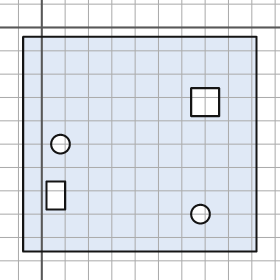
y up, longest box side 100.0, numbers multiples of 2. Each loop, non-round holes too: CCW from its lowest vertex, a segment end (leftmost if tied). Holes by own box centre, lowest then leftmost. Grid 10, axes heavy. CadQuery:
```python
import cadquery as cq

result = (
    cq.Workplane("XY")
    .moveTo(-8.0, -96.0)
    .lineTo(92.0, -96.0)
    .lineTo(92.0, -4.0)
    .lineTo(-8.0, -4.0)
    .close()
    .moveTo(68.0, -80.0)
    .circle(4.0)
    .moveTo(2.0, -78.0)
    .lineTo(10.0, -78.0)
    .lineTo(10.0, -66.0)
    .lineTo(2.0, -66.0)
    .close()
    .moveTo(8.0, -50.0)
    .circle(4.0)
    .moveTo(64.0, -38.0)
    .lineTo(76.0, -38.0)
    .lineTo(76.0, -26.0)
    .lineTo(64.0, -26.0)
    .close()
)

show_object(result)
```